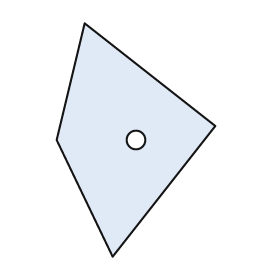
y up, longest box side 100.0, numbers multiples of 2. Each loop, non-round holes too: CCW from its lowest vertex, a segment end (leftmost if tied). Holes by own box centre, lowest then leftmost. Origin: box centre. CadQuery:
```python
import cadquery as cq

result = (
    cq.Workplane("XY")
    .moveTo(-10.0, -50.0)
    .lineTo(34.0, 6.0)
    .lineTo(-22.0, 50.0)
    .lineTo(-34.0, 0.0)
    .close()
    .moveTo(0.0, 0.0)
    .circle(4.0)
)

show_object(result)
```